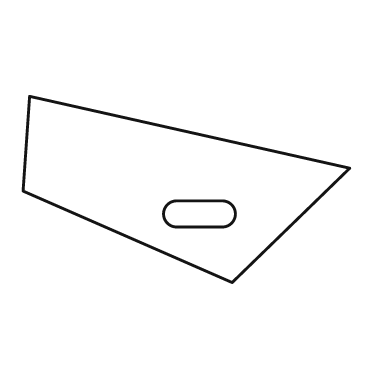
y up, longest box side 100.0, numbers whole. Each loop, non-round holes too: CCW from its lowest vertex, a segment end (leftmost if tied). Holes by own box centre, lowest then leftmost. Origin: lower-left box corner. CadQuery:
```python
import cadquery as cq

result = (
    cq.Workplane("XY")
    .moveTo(64.0, 0.0)
    .lineTo(100.0, 35.0)
    .lineTo(2.0, 57.0)
    .lineTo(0.0, 28.0)
    .close()
    .moveTo(47.0, 17.0)
    .lineTo(61.0, 17.0)
    .threePointArc((65.0, 21.0), (61.0, 25.0))
    .lineTo(47.0, 25.0)
    .threePointArc((43.0, 21.0), (47.0, 17.0))
    .close()
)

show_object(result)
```